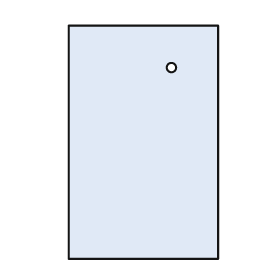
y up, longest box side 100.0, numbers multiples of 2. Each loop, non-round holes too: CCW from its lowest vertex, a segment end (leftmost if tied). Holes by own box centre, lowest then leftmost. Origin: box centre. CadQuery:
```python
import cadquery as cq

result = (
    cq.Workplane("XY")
    .moveTo(-32.0, -50.0)
    .lineTo(32.0, -50.0)
    .lineTo(32.0, 50.0)
    .lineTo(-32.0, 50.0)
    .close()
    .moveTo(12.0, 32.0)
    .circle(2.0)
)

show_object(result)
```